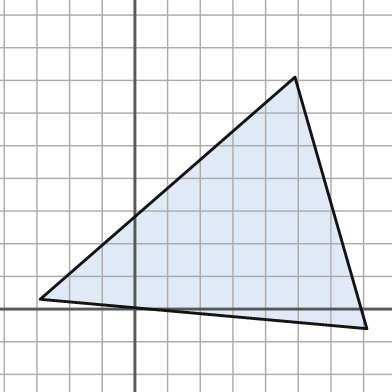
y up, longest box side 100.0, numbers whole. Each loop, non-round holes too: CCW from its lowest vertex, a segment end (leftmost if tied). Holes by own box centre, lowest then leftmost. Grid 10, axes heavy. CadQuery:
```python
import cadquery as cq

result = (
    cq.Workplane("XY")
    .moveTo(71.0, -6.0)
    .lineTo(49.0, 71.0)
    .lineTo(-29.0, 3.0)
    .close()
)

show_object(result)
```